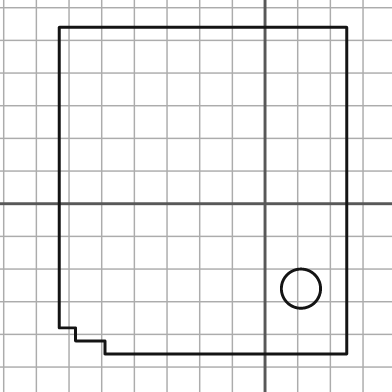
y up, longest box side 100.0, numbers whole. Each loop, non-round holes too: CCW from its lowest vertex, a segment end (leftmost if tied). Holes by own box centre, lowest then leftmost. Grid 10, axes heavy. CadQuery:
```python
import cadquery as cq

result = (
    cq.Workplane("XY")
    .moveTo(-49.0, -46.0)
    .lineTo(25.0, -46.0)
    .lineTo(25.0, 54.0)
    .lineTo(-63.0, 54.0)
    .lineTo(-63.0, -38.0)
    .lineTo(-58.0, -38.0)
    .lineTo(-58.0, -42.0)
    .lineTo(-49.0, -42.0)
    .close()
    .moveTo(11.0, -26.0)
    .circle(6.0)
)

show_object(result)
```